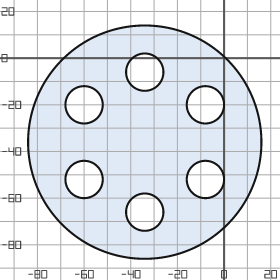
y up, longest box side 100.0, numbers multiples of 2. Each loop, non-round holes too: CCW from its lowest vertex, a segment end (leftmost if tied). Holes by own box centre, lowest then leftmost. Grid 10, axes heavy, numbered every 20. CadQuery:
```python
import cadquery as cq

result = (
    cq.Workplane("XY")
    .moveTo(-34.0, -36.0)
    .circle(50.0)
    .moveTo(-34.0, -66.0)
    .circle(8.0)
    .moveTo(-60.0, -52.0)
    .circle(8.0)
    .moveTo(-8.0, -52.0)
    .circle(8.0)
    .moveTo(-60.0, -20.0)
    .circle(8.0)
    .moveTo(-8.0, -20.0)
    .circle(8.0)
    .moveTo(-34.0, -6.0)
    .circle(8.0)
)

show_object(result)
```